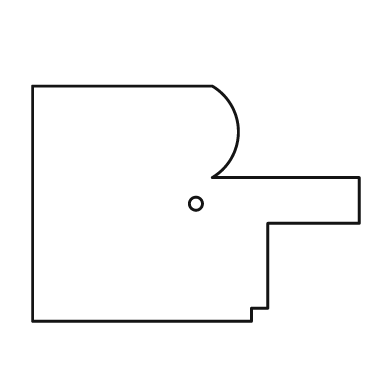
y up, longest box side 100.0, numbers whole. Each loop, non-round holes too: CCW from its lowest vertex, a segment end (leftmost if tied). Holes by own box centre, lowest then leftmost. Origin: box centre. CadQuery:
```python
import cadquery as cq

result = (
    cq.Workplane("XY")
    .moveTo(-50.0, -36.0)
    .lineTo(17.0, -36.0)
    .lineTo(17.0, -32.0)
    .lineTo(22.0, -32.0)
    .lineTo(22.0, -6.0)
    .lineTo(50.0, -6.0)
    .lineTo(50.0, 8.0)
    .lineTo(5.0, 8.0)
    .threePointArc((13.0, 22.0), (5.0, 36.0))
    .lineTo(-50.0, 36.0)
    .close()
    .moveTo(0.0, 0.0)
    .circle(2.0)
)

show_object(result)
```